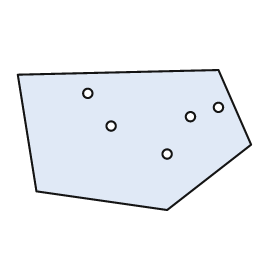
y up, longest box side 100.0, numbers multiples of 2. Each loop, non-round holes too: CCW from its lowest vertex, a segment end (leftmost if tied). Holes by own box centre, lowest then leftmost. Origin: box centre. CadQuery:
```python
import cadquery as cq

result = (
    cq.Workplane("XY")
    .moveTo(14.0, -30.0)
    .lineTo(50.0, -2.0)
    .lineTo(36.0, 30.0)
    .lineTo(-50.0, 28.0)
    .lineTo(-42.0, -22.0)
    .close()
    .moveTo(14.0, -6.0)
    .circle(2.0)
    .moveTo(-10.0, 6.0)
    .circle(2.0)
    .moveTo(24.0, 10.0)
    .circle(2.0)
    .moveTo(36.0, 14.0)
    .circle(2.0)
    .moveTo(-20.0, 20.0)
    .circle(2.0)
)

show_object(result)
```